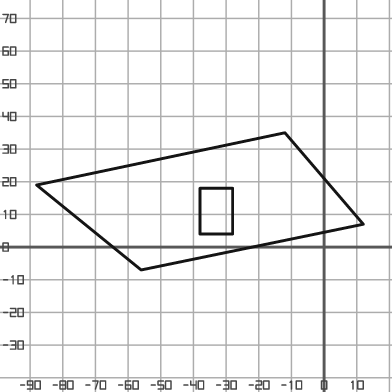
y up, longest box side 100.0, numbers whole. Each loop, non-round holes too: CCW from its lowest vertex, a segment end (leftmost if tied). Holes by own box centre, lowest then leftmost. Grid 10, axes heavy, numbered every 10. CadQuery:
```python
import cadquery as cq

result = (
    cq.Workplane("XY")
    .moveTo(-56.0, -7.0)
    .lineTo(12.0, 7.0)
    .lineTo(-12.0, 35.0)
    .lineTo(-88.0, 19.0)
    .close()
    .moveTo(-38.0, 4.0)
    .lineTo(-28.0, 4.0)
    .lineTo(-28.0, 18.0)
    .lineTo(-38.0, 18.0)
    .close()
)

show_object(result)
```